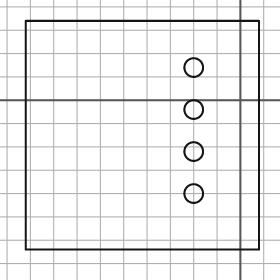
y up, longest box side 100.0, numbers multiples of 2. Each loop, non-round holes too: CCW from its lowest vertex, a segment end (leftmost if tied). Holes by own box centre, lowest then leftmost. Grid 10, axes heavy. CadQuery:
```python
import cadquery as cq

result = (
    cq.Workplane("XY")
    .moveTo(-92.0, -64.0)
    .lineTo(8.0, -64.0)
    .lineTo(8.0, 34.0)
    .lineTo(-92.0, 34.0)
    .close()
    .moveTo(-20.0, -40.0)
    .circle(4.0)
    .moveTo(-20.0, -22.0)
    .circle(4.0)
    .moveTo(-20.0, -4.0)
    .circle(4.0)
    .moveTo(-20.0, 14.0)
    .circle(4.0)
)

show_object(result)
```